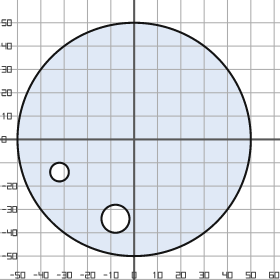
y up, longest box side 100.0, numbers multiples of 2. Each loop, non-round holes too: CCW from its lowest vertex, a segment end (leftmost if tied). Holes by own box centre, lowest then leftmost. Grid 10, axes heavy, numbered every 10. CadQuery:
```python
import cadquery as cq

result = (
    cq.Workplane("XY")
    .moveTo(0.0, 0.0)
    .circle(50.0)
    .moveTo(-8.0, -34.0)
    .circle(6.0)
    .moveTo(-32.0, -14.0)
    .circle(4.0)
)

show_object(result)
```